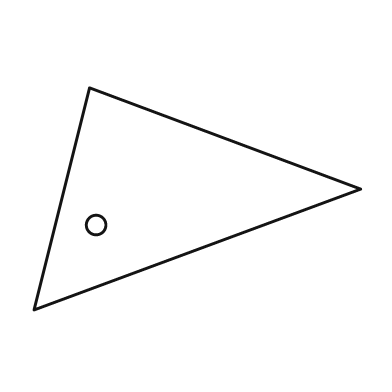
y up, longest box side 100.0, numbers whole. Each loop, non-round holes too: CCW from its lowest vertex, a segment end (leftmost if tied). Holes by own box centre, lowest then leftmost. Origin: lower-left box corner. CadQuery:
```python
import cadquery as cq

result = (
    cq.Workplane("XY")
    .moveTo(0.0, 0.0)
    .lineTo(100.0, 37.0)
    .lineTo(17.0, 68.0)
    .close()
    .moveTo(19.0, 26.0)
    .circle(3.0)
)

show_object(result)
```